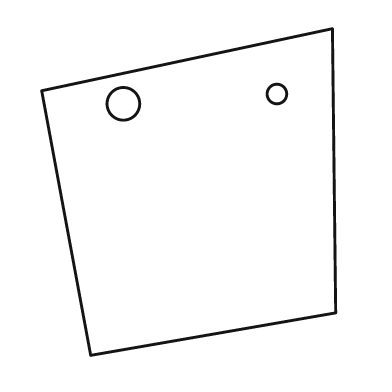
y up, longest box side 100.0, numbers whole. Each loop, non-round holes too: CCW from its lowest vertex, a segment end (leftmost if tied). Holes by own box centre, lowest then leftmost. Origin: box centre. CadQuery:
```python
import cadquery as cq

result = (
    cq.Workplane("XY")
    .moveTo(-30.0, -50.0)
    .lineTo(45.0, -37.0)
    .lineTo(44.0, 50.0)
    .lineTo(-45.0, 31.0)
    .close()
    .moveTo(-20.0, 27.0)
    .circle(5.0)
    .moveTo(27.0, 30.0)
    .circle(3.0)
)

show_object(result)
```